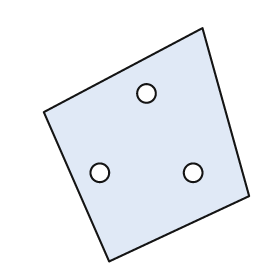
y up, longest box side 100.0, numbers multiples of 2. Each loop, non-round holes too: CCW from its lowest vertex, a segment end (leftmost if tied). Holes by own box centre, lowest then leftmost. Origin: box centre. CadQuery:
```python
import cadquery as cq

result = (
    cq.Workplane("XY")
    .moveTo(-16.0, -50.0)
    .lineTo(44.0, -22.0)
    .lineTo(24.0, 50.0)
    .lineTo(-44.0, 14.0)
    .close()
    .moveTo(-20.0, -12.0)
    .circle(4.0)
    .moveTo(20.0, -12.0)
    .circle(4.0)
    .moveTo(0.0, 22.0)
    .circle(4.0)
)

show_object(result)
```